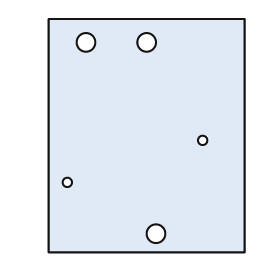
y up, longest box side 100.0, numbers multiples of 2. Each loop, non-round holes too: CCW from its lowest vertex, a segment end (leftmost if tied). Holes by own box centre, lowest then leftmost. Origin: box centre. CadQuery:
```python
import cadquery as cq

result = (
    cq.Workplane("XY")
    .moveTo(-42.0, -50.0)
    .lineTo(42.0, -50.0)
    .lineTo(42.0, 50.0)
    .lineTo(-42.0, 50.0)
    .close()
    .moveTo(4.0, -42.0)
    .circle(4.0)
    .moveTo(-34.0, -20.0)
    .circle(2.0)
    .moveTo(24.0, -2.0)
    .circle(2.0)
    .moveTo(-26.0, 40.0)
    .circle(4.0)
    .moveTo(0.0, 40.0)
    .circle(4.0)
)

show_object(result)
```